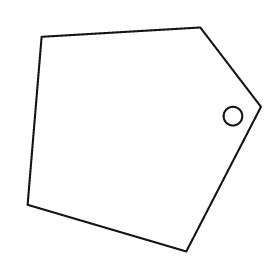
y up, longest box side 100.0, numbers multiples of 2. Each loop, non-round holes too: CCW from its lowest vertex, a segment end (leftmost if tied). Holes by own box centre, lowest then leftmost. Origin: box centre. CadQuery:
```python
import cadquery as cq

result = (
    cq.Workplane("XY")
    .moveTo(18.0, -48.0)
    .lineTo(50.0, 14.0)
    .lineTo(24.0, 48.0)
    .lineTo(-44.0, 44.0)
    .lineTo(-50.0, -28.0)
    .close()
    .moveTo(38.0, 10.0)
    .circle(4.0)
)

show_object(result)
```